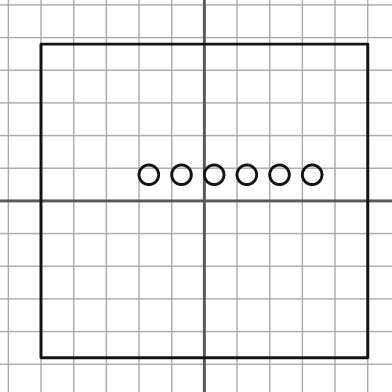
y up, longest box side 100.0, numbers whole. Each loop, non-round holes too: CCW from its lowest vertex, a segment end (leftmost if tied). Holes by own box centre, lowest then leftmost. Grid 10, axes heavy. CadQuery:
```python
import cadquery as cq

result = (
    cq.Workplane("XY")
    .moveTo(-50.0, -48.0)
    .lineTo(50.0, -48.0)
    .lineTo(50.0, 48.0)
    .lineTo(-50.0, 48.0)
    .close()
    .moveTo(-17.0, 8.0)
    .circle(3.0)
    .moveTo(-7.0, 8.0)
    .circle(3.0)
    .moveTo(3.0, 8.0)
    .circle(3.0)
    .moveTo(13.0, 8.0)
    .circle(3.0)
    .moveTo(23.0, 8.0)
    .circle(3.0)
    .moveTo(33.0, 8.0)
    .circle(3.0)
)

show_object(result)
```